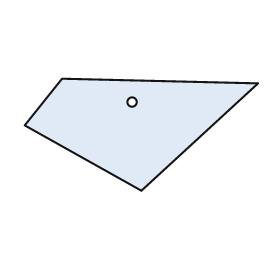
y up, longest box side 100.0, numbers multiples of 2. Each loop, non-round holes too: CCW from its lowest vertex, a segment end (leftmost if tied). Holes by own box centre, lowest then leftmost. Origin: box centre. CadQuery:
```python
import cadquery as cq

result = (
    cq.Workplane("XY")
    .moveTo(0.0, -24.0)
    .lineTo(50.0, 22.0)
    .lineTo(-34.0, 24.0)
    .lineTo(-50.0, 4.0)
    .close()
    .moveTo(-4.0, 14.0)
    .circle(2.0)
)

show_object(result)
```